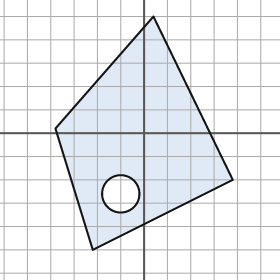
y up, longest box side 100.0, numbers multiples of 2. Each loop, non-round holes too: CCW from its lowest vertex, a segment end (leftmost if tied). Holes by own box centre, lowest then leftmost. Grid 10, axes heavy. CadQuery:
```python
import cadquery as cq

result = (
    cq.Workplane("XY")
    .moveTo(-22.0, -50.0)
    .lineTo(38.0, -20.0)
    .lineTo(4.0, 50.0)
    .lineTo(-38.0, 2.0)
    .close()
    .moveTo(-10.0, -26.0)
    .circle(8.0)
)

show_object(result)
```